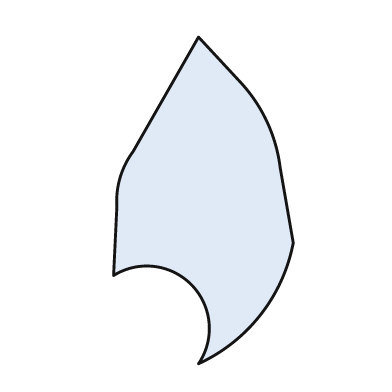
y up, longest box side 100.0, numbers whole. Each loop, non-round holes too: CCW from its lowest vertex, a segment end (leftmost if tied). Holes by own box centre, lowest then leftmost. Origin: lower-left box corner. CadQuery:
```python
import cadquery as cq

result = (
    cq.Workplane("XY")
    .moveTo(26.0, 0.0)
    .threePointArc((45.0, 15.0), (55.0, 37.0))
    .lineTo(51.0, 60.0)
    .threePointArc((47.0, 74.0), (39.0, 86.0))
    .lineTo(26.0, 100.0)
    .lineTo(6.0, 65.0)
    .threePointArc((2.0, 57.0), (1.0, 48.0))
    .lineTo(0.0, 27.0)
    .threePointArc((24.0, 24.0), (26.0, 0.0))
    .close()
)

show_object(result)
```